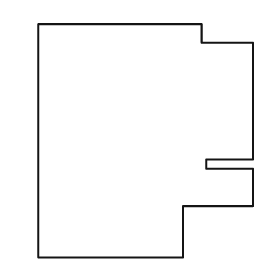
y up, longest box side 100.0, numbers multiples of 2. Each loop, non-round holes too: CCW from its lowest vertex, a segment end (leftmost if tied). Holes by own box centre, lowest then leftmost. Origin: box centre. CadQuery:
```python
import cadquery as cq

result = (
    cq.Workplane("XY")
    .moveTo(-46.0, -50.0)
    .lineTo(16.0, -50.0)
    .lineTo(16.0, -28.0)
    .lineTo(46.0, -28.0)
    .lineTo(46.0, -12.0)
    .lineTo(26.0, -12.0)
    .lineTo(26.0, -8.0)
    .lineTo(46.0, -8.0)
    .lineTo(46.0, 42.0)
    .lineTo(24.0, 42.0)
    .lineTo(24.0, 50.0)
    .lineTo(-46.0, 50.0)
    .close()
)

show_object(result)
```